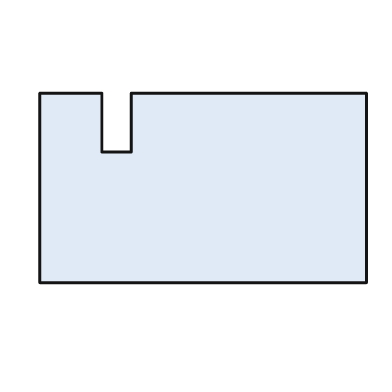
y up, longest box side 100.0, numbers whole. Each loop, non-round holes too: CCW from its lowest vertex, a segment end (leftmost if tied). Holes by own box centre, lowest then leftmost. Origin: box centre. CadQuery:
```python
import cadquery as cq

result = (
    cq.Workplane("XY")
    .moveTo(-50.0, -29.0)
    .lineTo(50.0, -29.0)
    .lineTo(50.0, 29.0)
    .lineTo(-22.0, 29.0)
    .lineTo(-22.0, 11.0)
    .lineTo(-31.0, 11.0)
    .lineTo(-31.0, 29.0)
    .lineTo(-50.0, 29.0)
    .close()
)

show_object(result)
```